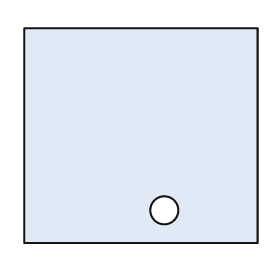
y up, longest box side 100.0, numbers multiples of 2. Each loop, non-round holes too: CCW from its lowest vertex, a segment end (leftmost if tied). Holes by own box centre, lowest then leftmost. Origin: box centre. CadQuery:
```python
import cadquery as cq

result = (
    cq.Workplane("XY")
    .moveTo(-50.0, -46.0)
    .lineTo(50.0, -46.0)
    .lineTo(50.0, 46.0)
    .lineTo(-50.0, 46.0)
    .close()
    .moveTo(10.0, -32.0)
    .circle(6.0)
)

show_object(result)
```